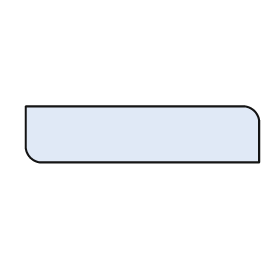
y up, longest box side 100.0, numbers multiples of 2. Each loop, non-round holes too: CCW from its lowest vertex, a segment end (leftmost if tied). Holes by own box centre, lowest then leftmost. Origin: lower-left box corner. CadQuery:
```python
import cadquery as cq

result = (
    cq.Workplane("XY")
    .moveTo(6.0, 0.0)
    .lineTo(100.0, 0.0)
    .lineTo(100.0, 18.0)
    .threePointArc((98.0, 22.0), (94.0, 24.0))
    .lineTo(0.0, 24.0)
    .lineTo(0.0, 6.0)
    .threePointArc((2.0, 2.0), (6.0, 0.0))
    .close()
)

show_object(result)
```